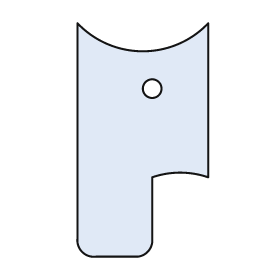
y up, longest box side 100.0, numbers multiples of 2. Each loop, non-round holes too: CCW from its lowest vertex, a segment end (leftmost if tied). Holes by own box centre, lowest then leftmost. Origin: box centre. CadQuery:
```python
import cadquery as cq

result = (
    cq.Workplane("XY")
    .moveTo(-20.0, -50.0)
    .lineTo(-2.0, -50.0)
    .threePointArc((2.0, -48.0), (4.0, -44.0))
    .lineTo(4.0, -16.0)
    .threePointArc((16.0, -14.0), (28.0, -16.0))
    .lineTo(28.0, 50.0)
    .threePointArc((0.0, 38.0), (-28.0, 50.0))
    .lineTo(-28.0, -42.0)
    .threePointArc((-26.0, -48.0), (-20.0, -50.0))
    .close()
    .moveTo(4.0, 22.0)
    .circle(4.0)
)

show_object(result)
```